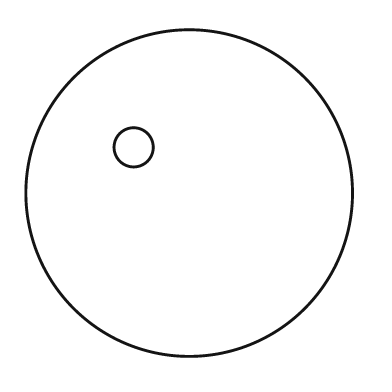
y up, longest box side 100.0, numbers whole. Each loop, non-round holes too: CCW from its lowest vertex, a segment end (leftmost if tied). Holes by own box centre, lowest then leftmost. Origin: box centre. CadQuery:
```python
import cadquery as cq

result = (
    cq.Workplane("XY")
    .moveTo(0.0, 0.0)
    .circle(50.0)
    .moveTo(-17.0, 14.0)
    .circle(6.0)
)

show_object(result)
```